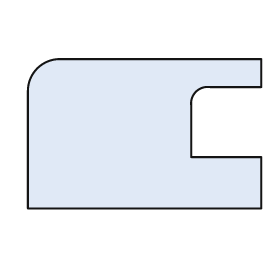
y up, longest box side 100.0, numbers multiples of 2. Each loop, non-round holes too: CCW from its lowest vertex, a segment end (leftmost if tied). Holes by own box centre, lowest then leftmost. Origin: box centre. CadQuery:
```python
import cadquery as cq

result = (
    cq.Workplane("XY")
    .moveTo(-50.0, -32.0)
    .lineTo(50.0, -32.0)
    .lineTo(50.0, -10.0)
    .lineTo(20.0, -10.0)
    .lineTo(20.0, 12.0)
    .threePointArc((22.0, 18.0), (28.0, 20.0))
    .lineTo(50.0, 20.0)
    .lineTo(50.0, 32.0)
    .lineTo(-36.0, 32.0)
    .threePointArc((-46.0, 28.0), (-50.0, 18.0))
    .close()
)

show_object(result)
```